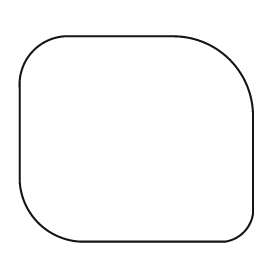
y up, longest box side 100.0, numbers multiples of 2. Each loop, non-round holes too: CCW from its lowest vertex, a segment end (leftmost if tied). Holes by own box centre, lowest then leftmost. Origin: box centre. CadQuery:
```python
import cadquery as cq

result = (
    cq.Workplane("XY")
    .moveTo(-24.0, -44.0)
    .lineTo(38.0, -44.0)
    .threePointArc((46.0, -40.0), (50.0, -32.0))
    .lineTo(50.0, 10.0)
    .threePointArc((40.0, 34.0), (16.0, 44.0))
    .lineTo(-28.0, 44.0)
    .threePointArc((-44.0, 38.0), (-50.0, 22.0))
    .lineTo(-50.0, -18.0)
    .threePointArc((-42.0, -36.0), (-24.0, -44.0))
    .close()
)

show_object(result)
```